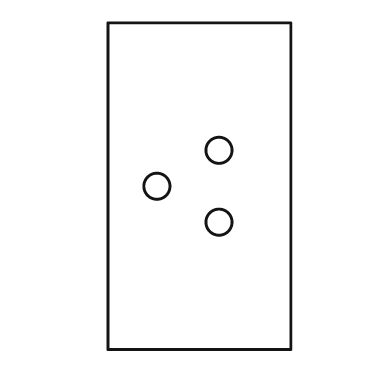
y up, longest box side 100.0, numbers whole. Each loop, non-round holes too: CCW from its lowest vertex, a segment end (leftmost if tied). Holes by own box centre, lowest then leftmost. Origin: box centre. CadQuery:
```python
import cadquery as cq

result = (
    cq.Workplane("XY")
    .moveTo(-28.0, -50.0)
    .lineTo(28.0, -50.0)
    .lineTo(28.0, 50.0)
    .lineTo(-28.0, 50.0)
    .close()
    .moveTo(6.0, -11.0)
    .circle(4.0)
    .moveTo(-13.0, 0.0)
    .circle(4.0)
    .moveTo(6.0, 11.0)
    .circle(4.0)
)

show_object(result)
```